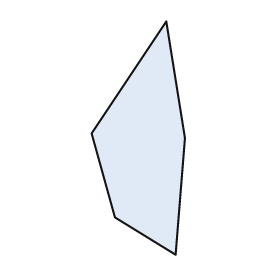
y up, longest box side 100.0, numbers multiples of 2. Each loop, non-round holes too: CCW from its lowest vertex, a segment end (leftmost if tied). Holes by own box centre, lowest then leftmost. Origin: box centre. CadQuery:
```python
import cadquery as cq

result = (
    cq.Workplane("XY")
    .moveTo(16.0, -50.0)
    .lineTo(20.0, 0.0)
    .lineTo(12.0, 50.0)
    .lineTo(-20.0, 2.0)
    .lineTo(-10.0, -34.0)
    .close()
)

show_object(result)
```